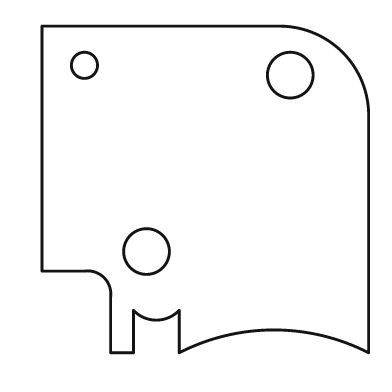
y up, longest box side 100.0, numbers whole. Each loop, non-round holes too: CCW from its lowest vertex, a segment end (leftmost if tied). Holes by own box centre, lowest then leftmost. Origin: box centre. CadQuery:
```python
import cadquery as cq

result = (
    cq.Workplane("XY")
    .moveTo(-29.0, -50.0)
    .lineTo(-22.0, -50.0)
    .lineTo(-22.0, -37.0)
    .threePointArc((-15.0, -40.0), (-8.0, -37.0))
    .lineTo(-8.0, -50.0)
    .threePointArc((21.0, -43.0), (50.0, -50.0))
    .lineTo(50.0, 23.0)
    .threePointArc((42.0, 42.0), (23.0, 50.0))
    .lineTo(-50.0, 50.0)
    .lineTo(-50.0, -25.0)
    .lineTo(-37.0, -25.0)
    .threePointArc((-31.0, -27.0), (-29.0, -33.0))
    .close()
    .moveTo(-18.0, -19.0)
    .circle(7.0)
    .moveTo(26.0, 35.0)
    .circle(7.0)
    .moveTo(-37.0, 38.0)
    .circle(4.0)
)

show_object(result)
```